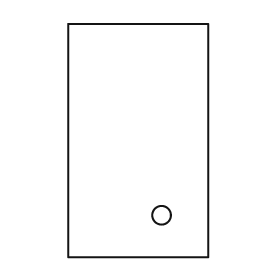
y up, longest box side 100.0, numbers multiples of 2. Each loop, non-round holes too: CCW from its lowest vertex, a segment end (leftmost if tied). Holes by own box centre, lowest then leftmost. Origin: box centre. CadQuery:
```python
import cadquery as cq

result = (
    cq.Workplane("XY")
    .moveTo(-30.0, -50.0)
    .lineTo(30.0, -50.0)
    .lineTo(30.0, 50.0)
    .lineTo(-30.0, 50.0)
    .close()
    .moveTo(10.0, -32.0)
    .circle(4.0)
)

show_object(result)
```